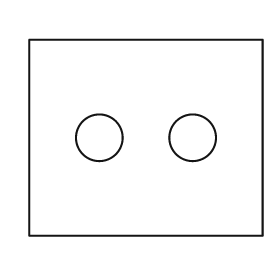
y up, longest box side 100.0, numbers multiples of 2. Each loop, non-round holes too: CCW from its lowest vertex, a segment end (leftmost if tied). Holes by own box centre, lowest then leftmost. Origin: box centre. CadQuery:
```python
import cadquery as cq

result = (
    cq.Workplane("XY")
    .moveTo(-50.0, -42.0)
    .lineTo(50.0, -42.0)
    .lineTo(50.0, 42.0)
    .lineTo(-50.0, 42.0)
    .close()
    .moveTo(-20.0, 0.0)
    .circle(10.0)
    .moveTo(20.0, 0.0)
    .circle(10.0)
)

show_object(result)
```